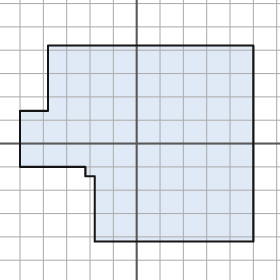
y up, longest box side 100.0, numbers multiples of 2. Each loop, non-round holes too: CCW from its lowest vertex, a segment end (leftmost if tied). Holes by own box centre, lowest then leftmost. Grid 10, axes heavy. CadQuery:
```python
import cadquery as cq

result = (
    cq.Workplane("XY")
    .moveTo(-18.0, -42.0)
    .lineTo(50.0, -42.0)
    .lineTo(50.0, 42.0)
    .lineTo(-38.0, 42.0)
    .lineTo(-38.0, 14.0)
    .lineTo(-50.0, 14.0)
    .lineTo(-50.0, -10.0)
    .lineTo(-22.0, -10.0)
    .lineTo(-22.0, -14.0)
    .lineTo(-18.0, -14.0)
    .close()
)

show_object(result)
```